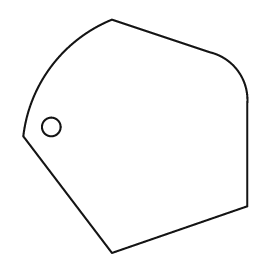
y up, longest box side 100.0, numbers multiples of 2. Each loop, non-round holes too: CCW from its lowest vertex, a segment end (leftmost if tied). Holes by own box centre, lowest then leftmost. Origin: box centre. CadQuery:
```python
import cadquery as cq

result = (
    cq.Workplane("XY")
    .moveTo(-10.0, -50.0)
    .lineTo(48.0, -30.0)
    .lineTo(48.0, 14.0)
    .threePointArc((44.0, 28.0), (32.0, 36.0))
    .lineTo(-10.0, 50.0)
    .threePointArc((-36.0, 30.0), (-48.0, 0.0))
    .close()
    .moveTo(-36.0, 4.0)
    .circle(4.0)
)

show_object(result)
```